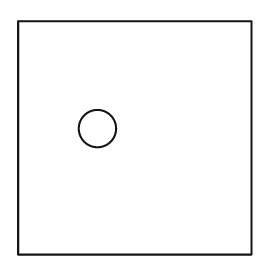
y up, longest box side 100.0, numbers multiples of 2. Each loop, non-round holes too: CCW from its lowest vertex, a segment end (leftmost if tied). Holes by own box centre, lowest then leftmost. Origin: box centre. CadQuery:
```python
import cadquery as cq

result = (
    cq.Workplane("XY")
    .moveTo(-50.0, -50.0)
    .lineTo(50.0, -50.0)
    .lineTo(50.0, 50.0)
    .lineTo(-50.0, 50.0)
    .close()
    .moveTo(-16.0, 4.0)
    .circle(8.0)
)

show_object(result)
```